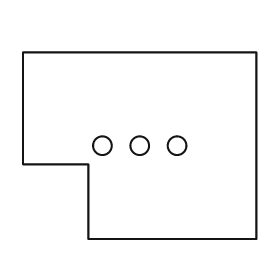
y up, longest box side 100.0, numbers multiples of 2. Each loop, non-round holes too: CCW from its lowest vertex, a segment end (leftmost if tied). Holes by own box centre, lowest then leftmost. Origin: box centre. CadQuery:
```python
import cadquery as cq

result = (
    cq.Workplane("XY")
    .moveTo(-22.0, -40.0)
    .lineTo(50.0, -40.0)
    .lineTo(50.0, 40.0)
    .lineTo(-50.0, 40.0)
    .lineTo(-50.0, -8.0)
    .lineTo(-22.0, -8.0)
    .close()
    .moveTo(-16.0, 0.0)
    .circle(4.0)
    .moveTo(0.0, 0.0)
    .circle(4.0)
    .moveTo(16.0, 0.0)
    .circle(4.0)
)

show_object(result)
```